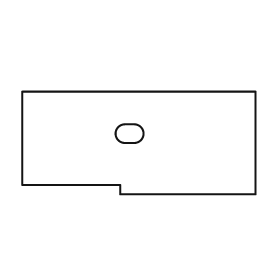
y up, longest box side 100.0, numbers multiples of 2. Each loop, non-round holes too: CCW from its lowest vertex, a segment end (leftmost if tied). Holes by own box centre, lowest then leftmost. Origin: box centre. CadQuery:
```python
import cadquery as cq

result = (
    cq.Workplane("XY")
    .moveTo(-8.0, -22.0)
    .lineTo(50.0, -22.0)
    .lineTo(50.0, 22.0)
    .lineTo(-50.0, 22.0)
    .lineTo(-50.0, -18.0)
    .lineTo(-8.0, -18.0)
    .close()
    .moveTo(-6.0, 0.0)
    .lineTo(-2.0, 0.0)
    .threePointArc((2.0, 4.0), (-2.0, 8.0))
    .lineTo(-6.0, 8.0)
    .threePointArc((-10.0, 4.0), (-6.0, 0.0))
    .close()
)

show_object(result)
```